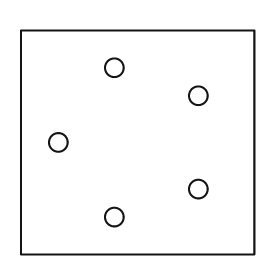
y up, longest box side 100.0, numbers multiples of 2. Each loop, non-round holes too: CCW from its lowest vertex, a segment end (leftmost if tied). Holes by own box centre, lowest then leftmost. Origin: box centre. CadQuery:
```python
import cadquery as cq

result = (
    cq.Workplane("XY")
    .moveTo(-50.0, -48.0)
    .lineTo(50.0, -48.0)
    .lineTo(50.0, 48.0)
    .lineTo(-50.0, 48.0)
    .close()
    .moveTo(-10.0, -32.0)
    .circle(4.0)
    .moveTo(26.0, -20.0)
    .circle(4.0)
    .moveTo(-34.0, 0.0)
    .circle(4.0)
    .moveTo(26.0, 20.0)
    .circle(4.0)
    .moveTo(-10.0, 32.0)
    .circle(4.0)
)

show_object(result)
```